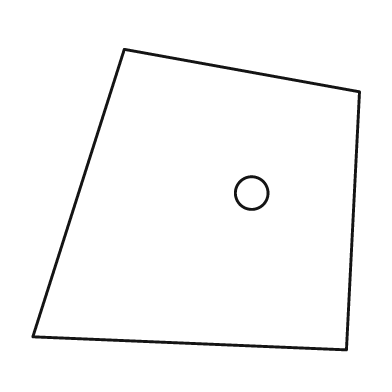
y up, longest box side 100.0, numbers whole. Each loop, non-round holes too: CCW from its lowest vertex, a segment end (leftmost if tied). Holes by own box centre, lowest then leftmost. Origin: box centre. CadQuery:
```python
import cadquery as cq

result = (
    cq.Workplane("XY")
    .moveTo(46.0, -46.0)
    .lineTo(50.0, 33.0)
    .lineTo(-22.0, 46.0)
    .lineTo(-50.0, -42.0)
    .close()
    .moveTo(17.0, 2.0)
    .circle(5.0)
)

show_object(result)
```